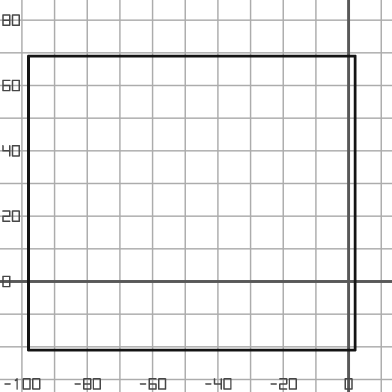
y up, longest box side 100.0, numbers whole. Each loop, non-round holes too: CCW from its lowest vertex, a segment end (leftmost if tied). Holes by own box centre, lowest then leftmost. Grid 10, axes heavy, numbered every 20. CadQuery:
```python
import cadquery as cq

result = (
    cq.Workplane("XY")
    .moveTo(-98.0, -21.0)
    .lineTo(2.0, -21.0)
    .lineTo(2.0, 69.0)
    .lineTo(-98.0, 69.0)
    .close()
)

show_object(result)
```